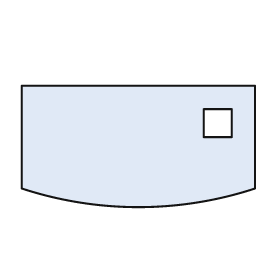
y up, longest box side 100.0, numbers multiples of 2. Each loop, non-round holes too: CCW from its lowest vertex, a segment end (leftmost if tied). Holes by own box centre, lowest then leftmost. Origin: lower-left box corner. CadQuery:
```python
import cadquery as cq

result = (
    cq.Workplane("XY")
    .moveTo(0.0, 8.0)
    .threePointArc((50.0, 0.0), (100.0, 8.0))
    .lineTo(100.0, 52.0)
    .lineTo(0.0, 52.0)
    .close()
    .moveTo(78.0, 30.0)
    .lineTo(90.0, 30.0)
    .lineTo(90.0, 42.0)
    .lineTo(78.0, 42.0)
    .close()
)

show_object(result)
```